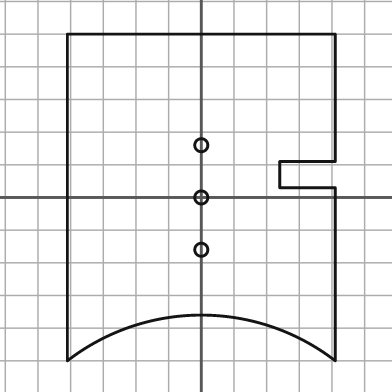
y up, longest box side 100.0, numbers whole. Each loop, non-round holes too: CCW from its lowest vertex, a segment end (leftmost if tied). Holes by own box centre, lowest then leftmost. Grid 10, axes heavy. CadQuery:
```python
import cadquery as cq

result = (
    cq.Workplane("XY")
    .moveTo(-41.0, -50.0)
    .threePointArc((0.0, -36.0), (41.0, -50.0))
    .lineTo(41.0, 3.0)
    .lineTo(24.0, 3.0)
    .lineTo(24.0, 11.0)
    .lineTo(41.0, 11.0)
    .lineTo(41.0, 50.0)
    .lineTo(-41.0, 50.0)
    .close()
    .moveTo(0.0, -16.0)
    .circle(2.0)
    .moveTo(0.0, 0.0)
    .circle(2.0)
    .moveTo(0.0, 16.0)
    .circle(2.0)
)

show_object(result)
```